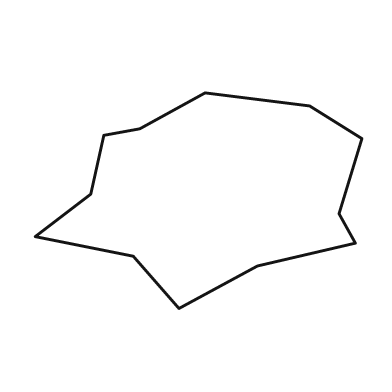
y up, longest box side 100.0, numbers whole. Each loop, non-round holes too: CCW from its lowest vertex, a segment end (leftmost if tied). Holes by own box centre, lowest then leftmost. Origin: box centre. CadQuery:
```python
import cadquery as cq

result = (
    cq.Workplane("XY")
    .moveTo(-6.0, -33.0)
    .lineTo(18.0, -20.0)
    .lineTo(48.0, -13.0)
    .lineTo(43.0, -4.0)
    .lineTo(50.0, 19.0)
    .lineTo(34.0, 29.0)
    .lineTo(2.0, 33.0)
    .lineTo(-18.0, 22.0)
    .lineTo(-29.0, 20.0)
    .lineTo(-33.0, 2.0)
    .lineTo(-50.0, -11.0)
    .lineTo(-20.0, -17.0)
    .close()
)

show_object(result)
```